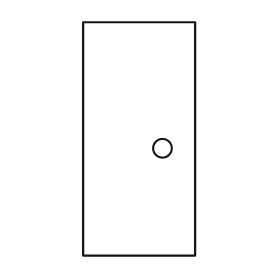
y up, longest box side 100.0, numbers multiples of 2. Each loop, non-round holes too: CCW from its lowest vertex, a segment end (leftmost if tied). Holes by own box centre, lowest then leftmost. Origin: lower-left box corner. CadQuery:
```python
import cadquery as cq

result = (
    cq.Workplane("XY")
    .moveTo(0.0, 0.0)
    .lineTo(48.0, 0.0)
    .lineTo(48.0, 100.0)
    .lineTo(0.0, 100.0)
    .close()
    .moveTo(34.0, 46.0)
    .circle(4.0)
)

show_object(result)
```